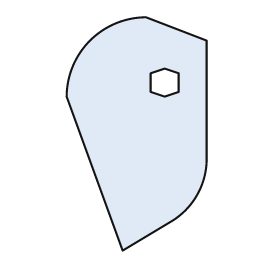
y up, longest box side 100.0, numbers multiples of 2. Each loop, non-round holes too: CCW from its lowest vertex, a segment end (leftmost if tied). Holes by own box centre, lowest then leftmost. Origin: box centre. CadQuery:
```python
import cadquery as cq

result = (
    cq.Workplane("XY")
    .moveTo(-6.0, -50.0)
    .lineTo(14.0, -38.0)
    .threePointArc((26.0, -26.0), (30.0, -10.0))
    .lineTo(30.0, 40.0)
    .lineTo(4.0, 50.0)
    .threePointArc((-20.0, 40.0), (-30.0, 16.0))
    .close()
    .moveTo(12.0, 16.0)
    .lineTo(18.0, 18.0)
    .lineTo(18.0, 26.0)
    .lineTo(12.0, 28.0)
    .lineTo(6.0, 26.0)
    .lineTo(6.0, 18.0)
    .close()
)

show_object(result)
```